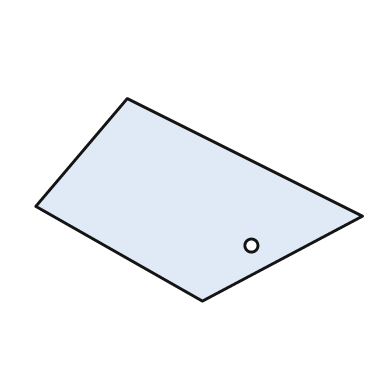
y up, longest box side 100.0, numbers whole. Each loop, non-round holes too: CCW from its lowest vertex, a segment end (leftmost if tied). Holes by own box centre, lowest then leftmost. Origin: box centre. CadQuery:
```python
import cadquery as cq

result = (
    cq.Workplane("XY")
    .moveTo(1.0, -31.0)
    .lineTo(50.0, -5.0)
    .lineTo(-22.0, 31.0)
    .lineTo(-50.0, -2.0)
    .close()
    .moveTo(16.0, -14.0)
    .circle(2.0)
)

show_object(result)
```